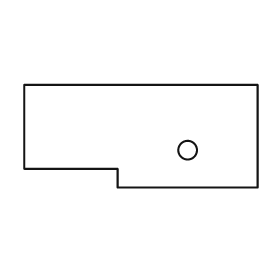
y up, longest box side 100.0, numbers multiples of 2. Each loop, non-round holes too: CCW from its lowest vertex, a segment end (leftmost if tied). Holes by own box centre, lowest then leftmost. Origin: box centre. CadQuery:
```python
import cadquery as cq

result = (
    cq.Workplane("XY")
    .moveTo(-10.0, -22.0)
    .lineTo(50.0, -22.0)
    .lineTo(50.0, 22.0)
    .lineTo(-50.0, 22.0)
    .lineTo(-50.0, -14.0)
    .lineTo(-10.0, -14.0)
    .close()
    .moveTo(20.0, -6.0)
    .circle(4.0)
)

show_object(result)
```